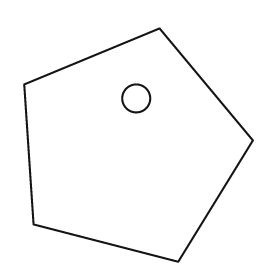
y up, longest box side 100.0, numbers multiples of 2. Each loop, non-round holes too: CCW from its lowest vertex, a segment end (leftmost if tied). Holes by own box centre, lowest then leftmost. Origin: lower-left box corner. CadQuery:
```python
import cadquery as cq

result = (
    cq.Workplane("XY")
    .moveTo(66.0, 0.0)
    .lineTo(98.0, 52.0)
    .lineTo(58.0, 100.0)
    .lineTo(0.0, 76.0)
    .lineTo(4.0, 16.0)
    .close()
    .moveTo(48.0, 70.0)
    .circle(6.0)
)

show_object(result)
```